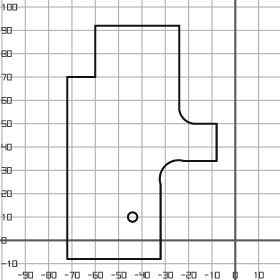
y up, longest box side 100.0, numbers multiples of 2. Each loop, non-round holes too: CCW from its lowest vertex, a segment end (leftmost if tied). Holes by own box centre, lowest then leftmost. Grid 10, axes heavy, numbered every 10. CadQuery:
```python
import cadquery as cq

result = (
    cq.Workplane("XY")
    .moveTo(-72.0, -8.0)
    .lineTo(-32.0, -8.0)
    .lineTo(-32.0, 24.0)
    .threePointArc((-30.0, 32.0), (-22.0, 34.0))
    .lineTo(-8.0, 34.0)
    .lineTo(-8.0, 50.0)
    .lineTo(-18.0, 50.0)
    .threePointArc((-22.0, 52.0), (-24.0, 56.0))
    .lineTo(-24.0, 92.0)
    .lineTo(-60.0, 92.0)
    .lineTo(-60.0, 70.0)
    .lineTo(-72.0, 70.0)
    .close()
    .moveTo(-44.0, 10.0)
    .circle(2.0)
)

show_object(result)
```